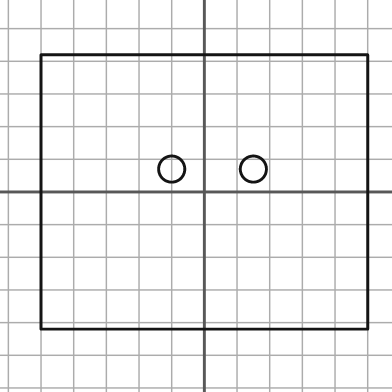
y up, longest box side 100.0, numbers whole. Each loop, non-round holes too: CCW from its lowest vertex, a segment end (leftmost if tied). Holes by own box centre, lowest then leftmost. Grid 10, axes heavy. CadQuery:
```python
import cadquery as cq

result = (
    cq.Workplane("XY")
    .moveTo(-50.0, -42.0)
    .lineTo(50.0, -42.0)
    .lineTo(50.0, 42.0)
    .lineTo(-50.0, 42.0)
    .close()
    .moveTo(-10.0, 7.0)
    .circle(4.0)
    .moveTo(15.0, 7.0)
    .circle(4.0)
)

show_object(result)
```